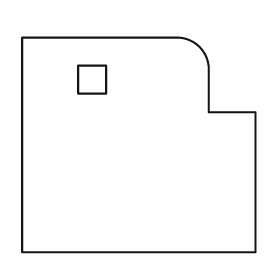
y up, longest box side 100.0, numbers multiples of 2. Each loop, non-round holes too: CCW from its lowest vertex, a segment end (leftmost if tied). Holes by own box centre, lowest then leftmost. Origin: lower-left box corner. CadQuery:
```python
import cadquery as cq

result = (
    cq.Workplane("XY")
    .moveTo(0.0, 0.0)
    .lineTo(100.0, 0.0)
    .lineTo(100.0, 60.0)
    .lineTo(80.0, 60.0)
    .lineTo(80.0, 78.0)
    .threePointArc((76.0, 88.0), (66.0, 92.0))
    .lineTo(0.0, 92.0)
    .close()
    .moveTo(24.0, 68.0)
    .lineTo(36.0, 68.0)
    .lineTo(36.0, 80.0)
    .lineTo(24.0, 80.0)
    .close()
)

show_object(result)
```